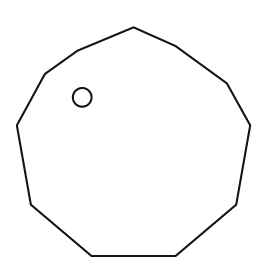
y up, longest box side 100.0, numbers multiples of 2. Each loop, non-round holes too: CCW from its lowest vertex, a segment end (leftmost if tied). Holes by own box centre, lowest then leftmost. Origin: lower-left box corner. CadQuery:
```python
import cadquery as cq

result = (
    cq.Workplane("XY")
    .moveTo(32.0, 0.0)
    .lineTo(68.0, 0.0)
    .lineTo(94.0, 22.0)
    .lineTo(100.0, 56.0)
    .lineTo(90.0, 74.0)
    .lineTo(68.0, 90.0)
    .lineTo(50.0, 98.0)
    .lineTo(26.0, 88.0)
    .lineTo(12.0, 78.0)
    .lineTo(0.0, 56.0)
    .lineTo(6.0, 22.0)
    .close()
    .moveTo(28.0, 68.0)
    .circle(4.0)
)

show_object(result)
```